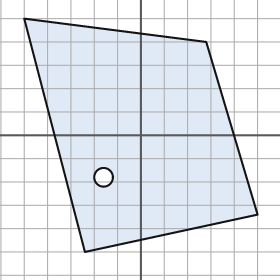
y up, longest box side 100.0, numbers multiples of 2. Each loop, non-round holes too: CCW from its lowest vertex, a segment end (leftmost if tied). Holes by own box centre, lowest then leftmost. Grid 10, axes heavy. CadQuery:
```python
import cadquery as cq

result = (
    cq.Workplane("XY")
    .moveTo(-24.0, -50.0)
    .lineTo(50.0, -34.0)
    .lineTo(28.0, 40.0)
    .lineTo(-50.0, 50.0)
    .close()
    .moveTo(-16.0, -18.0)
    .circle(4.0)
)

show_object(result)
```